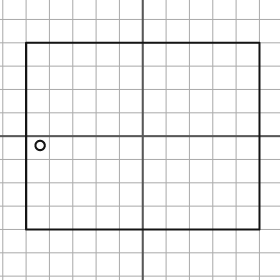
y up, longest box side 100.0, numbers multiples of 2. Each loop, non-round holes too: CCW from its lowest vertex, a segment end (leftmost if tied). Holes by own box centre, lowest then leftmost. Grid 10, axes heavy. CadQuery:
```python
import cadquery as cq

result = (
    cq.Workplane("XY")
    .moveTo(-50.0, -40.0)
    .lineTo(50.0, -40.0)
    .lineTo(50.0, 40.0)
    .lineTo(-50.0, 40.0)
    .close()
    .moveTo(-44.0, -4.0)
    .circle(2.0)
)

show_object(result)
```